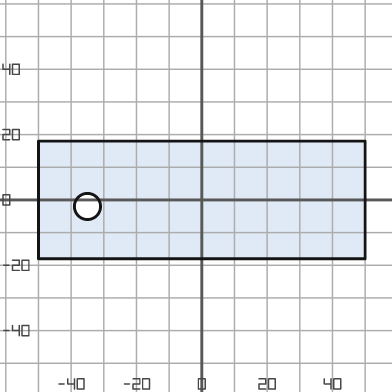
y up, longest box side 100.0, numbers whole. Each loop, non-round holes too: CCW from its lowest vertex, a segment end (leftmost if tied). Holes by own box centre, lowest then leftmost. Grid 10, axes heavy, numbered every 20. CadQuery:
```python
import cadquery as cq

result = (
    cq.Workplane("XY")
    .moveTo(-50.0, -18.0)
    .lineTo(50.0, -18.0)
    .lineTo(50.0, 18.0)
    .lineTo(-50.0, 18.0)
    .close()
    .moveTo(-35.0, -2.0)
    .circle(4.0)
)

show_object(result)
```